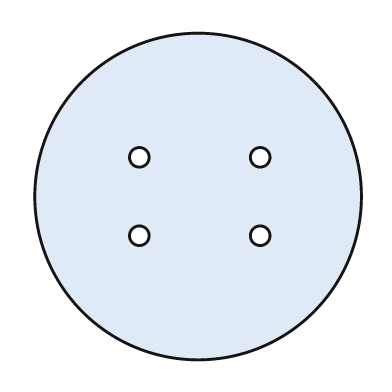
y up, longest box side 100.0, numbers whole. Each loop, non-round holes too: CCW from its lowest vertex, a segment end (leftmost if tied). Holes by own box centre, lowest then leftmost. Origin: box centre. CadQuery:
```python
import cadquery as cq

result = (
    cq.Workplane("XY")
    .moveTo(0.0, 0.0)
    .circle(50.0)
    .moveTo(-18.0, -12.0)
    .circle(3.0)
    .moveTo(19.0, -12.0)
    .circle(3.0)
    .moveTo(-18.0, 12.0)
    .circle(3.0)
    .moveTo(19.0, 12.0)
    .circle(3.0)
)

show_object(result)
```